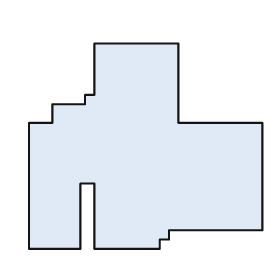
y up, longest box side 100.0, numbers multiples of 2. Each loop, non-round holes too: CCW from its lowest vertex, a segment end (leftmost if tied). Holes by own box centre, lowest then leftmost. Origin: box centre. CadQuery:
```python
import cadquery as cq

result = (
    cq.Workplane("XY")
    .moveTo(-50.0, -44.0)
    .lineTo(-28.0, -44.0)
    .lineTo(-28.0, -16.0)
    .lineTo(-22.0, -16.0)
    .lineTo(-22.0, -44.0)
    .lineTo(6.0, -44.0)
    .lineTo(6.0, -40.0)
    .lineTo(10.0, -40.0)
    .lineTo(10.0, -36.0)
    .lineTo(50.0, -36.0)
    .lineTo(50.0, 10.0)
    .lineTo(14.0, 10.0)
    .lineTo(14.0, 44.0)
    .lineTo(-22.0, 44.0)
    .lineTo(-22.0, 22.0)
    .lineTo(-26.0, 22.0)
    .lineTo(-26.0, 18.0)
    .lineTo(-40.0, 18.0)
    .lineTo(-40.0, 10.0)
    .lineTo(-50.0, 10.0)
    .close()
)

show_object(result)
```